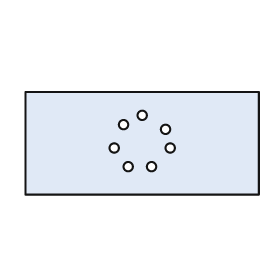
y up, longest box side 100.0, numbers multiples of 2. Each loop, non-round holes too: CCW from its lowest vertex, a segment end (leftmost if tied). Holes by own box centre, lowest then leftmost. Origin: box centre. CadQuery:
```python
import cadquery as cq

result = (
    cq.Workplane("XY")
    .moveTo(-50.0, -22.0)
    .lineTo(50.0, -22.0)
    .lineTo(50.0, 22.0)
    .lineTo(-50.0, 22.0)
    .close()
    .moveTo(-6.0, -10.0)
    .circle(2.0)
    .moveTo(4.0, -10.0)
    .circle(2.0)
    .moveTo(-12.0, -2.0)
    .circle(2.0)
    .moveTo(12.0, -2.0)
    .circle(2.0)
    .moveTo(10.0, 6.0)
    .circle(2.0)
    .moveTo(-8.0, 8.0)
    .circle(2.0)
    .moveTo(0.0, 12.0)
    .circle(2.0)
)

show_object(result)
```